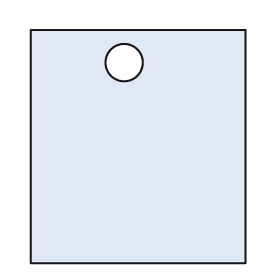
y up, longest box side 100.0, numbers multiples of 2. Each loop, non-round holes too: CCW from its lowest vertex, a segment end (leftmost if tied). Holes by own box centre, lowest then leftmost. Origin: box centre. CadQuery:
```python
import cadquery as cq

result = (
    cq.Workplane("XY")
    .moveTo(-46.0, -50.0)
    .lineTo(46.0, -50.0)
    .lineTo(46.0, 50.0)
    .lineTo(-46.0, 50.0)
    .close()
    .moveTo(-6.0, 36.0)
    .circle(8.0)
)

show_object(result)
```